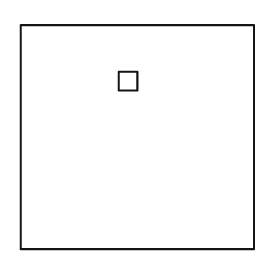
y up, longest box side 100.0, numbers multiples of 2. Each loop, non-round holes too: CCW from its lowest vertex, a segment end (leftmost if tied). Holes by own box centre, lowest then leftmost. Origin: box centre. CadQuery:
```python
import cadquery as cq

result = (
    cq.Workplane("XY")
    .moveTo(-50.0, -48.0)
    .lineTo(50.0, -48.0)
    .lineTo(50.0, 48.0)
    .lineTo(-50.0, 48.0)
    .close()
    .moveTo(-8.0, 20.0)
    .lineTo(0.0, 20.0)
    .lineTo(0.0, 28.0)
    .lineTo(-8.0, 28.0)
    .close()
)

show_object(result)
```